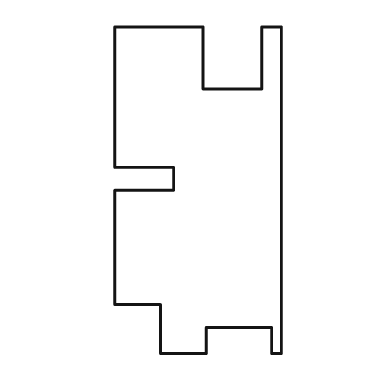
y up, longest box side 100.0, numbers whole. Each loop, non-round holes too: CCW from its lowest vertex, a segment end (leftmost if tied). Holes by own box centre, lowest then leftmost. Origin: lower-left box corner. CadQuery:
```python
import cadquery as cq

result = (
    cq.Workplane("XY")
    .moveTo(14.0, 0.0)
    .lineTo(28.0, 0.0)
    .lineTo(28.0, 8.0)
    .lineTo(48.0, 8.0)
    .lineTo(48.0, 0.0)
    .lineTo(51.0, 0.0)
    .lineTo(51.0, 100.0)
    .lineTo(45.0, 100.0)
    .lineTo(45.0, 81.0)
    .lineTo(27.0, 81.0)
    .lineTo(27.0, 100.0)
    .lineTo(0.0, 100.0)
    .lineTo(0.0, 57.0)
    .lineTo(18.0, 57.0)
    .lineTo(18.0, 50.0)
    .lineTo(0.0, 50.0)
    .lineTo(0.0, 15.0)
    .lineTo(14.0, 15.0)
    .close()
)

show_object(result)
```